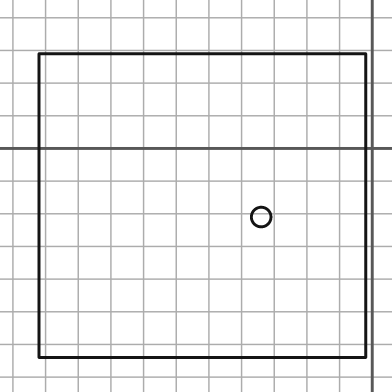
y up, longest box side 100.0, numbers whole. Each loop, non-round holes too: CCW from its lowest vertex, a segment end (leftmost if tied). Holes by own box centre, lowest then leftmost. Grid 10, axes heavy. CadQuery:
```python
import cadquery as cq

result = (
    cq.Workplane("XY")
    .moveTo(-102.0, -64.0)
    .lineTo(-2.0, -64.0)
    .lineTo(-2.0, 29.0)
    .lineTo(-102.0, 29.0)
    .close()
    .moveTo(-34.0, -21.0)
    .circle(3.0)
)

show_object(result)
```